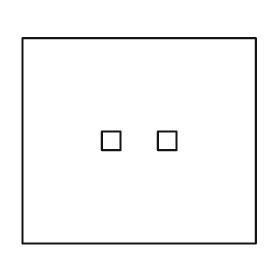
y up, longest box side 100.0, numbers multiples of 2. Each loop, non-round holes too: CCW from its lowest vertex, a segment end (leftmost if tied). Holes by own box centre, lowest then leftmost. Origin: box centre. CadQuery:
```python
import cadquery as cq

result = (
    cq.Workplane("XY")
    .moveTo(-50.0, -44.0)
    .lineTo(50.0, -44.0)
    .lineTo(50.0, 44.0)
    .lineTo(-50.0, 44.0)
    .close()
    .moveTo(-16.0, -4.0)
    .lineTo(-8.0, -4.0)
    .lineTo(-8.0, 4.0)
    .lineTo(-16.0, 4.0)
    .close()
    .moveTo(8.0, -4.0)
    .lineTo(16.0, -4.0)
    .lineTo(16.0, 4.0)
    .lineTo(8.0, 4.0)
    .close()
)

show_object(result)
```